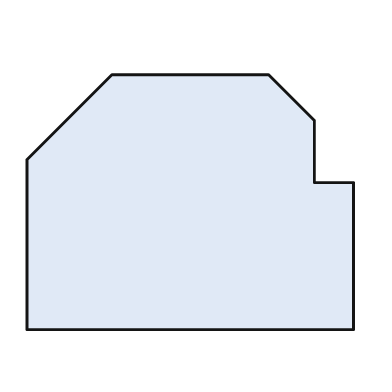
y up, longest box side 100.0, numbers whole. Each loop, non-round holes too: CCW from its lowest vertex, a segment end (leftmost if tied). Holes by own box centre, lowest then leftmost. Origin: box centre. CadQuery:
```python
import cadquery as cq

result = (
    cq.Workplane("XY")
    .moveTo(-50.0, -39.0)
    .lineTo(50.0, -39.0)
    .lineTo(50.0, 6.0)
    .lineTo(38.0, 6.0)
    .lineTo(38.0, 25.0)
    .lineTo(24.0, 39.0)
    .lineTo(-24.0, 39.0)
    .lineTo(-50.0, 13.0)
    .close()
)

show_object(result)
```